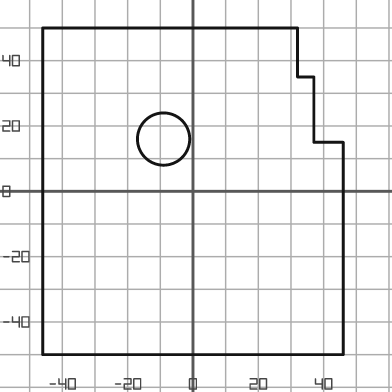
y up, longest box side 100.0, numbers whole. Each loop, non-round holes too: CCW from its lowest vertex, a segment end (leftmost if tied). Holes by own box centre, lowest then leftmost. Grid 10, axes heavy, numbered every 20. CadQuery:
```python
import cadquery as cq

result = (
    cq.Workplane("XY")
    .moveTo(-46.0, -50.0)
    .lineTo(46.0, -50.0)
    .lineTo(46.0, 15.0)
    .lineTo(37.0, 15.0)
    .lineTo(37.0, 35.0)
    .lineTo(32.0, 35.0)
    .lineTo(32.0, 50.0)
    .lineTo(-46.0, 50.0)
    .close()
    .moveTo(-9.0, 16.0)
    .circle(8.0)
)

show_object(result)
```